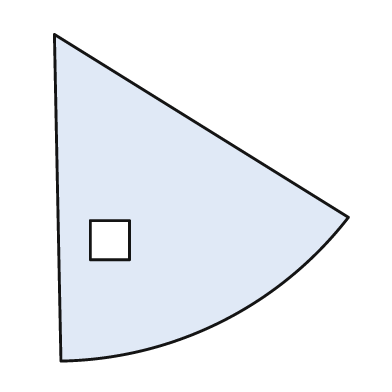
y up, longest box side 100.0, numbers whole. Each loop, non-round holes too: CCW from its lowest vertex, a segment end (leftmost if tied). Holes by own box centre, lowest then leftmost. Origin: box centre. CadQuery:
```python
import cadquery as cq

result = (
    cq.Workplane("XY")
    .moveTo(-43.0, -50.0)
    .threePointArc((6.0, -38.0), (45.0, -6.0))
    .lineTo(-45.0, 50.0)
    .close()
    .moveTo(-34.0, -19.0)
    .lineTo(-22.0, -19.0)
    .lineTo(-22.0, -7.0)
    .lineTo(-34.0, -7.0)
    .close()
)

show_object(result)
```